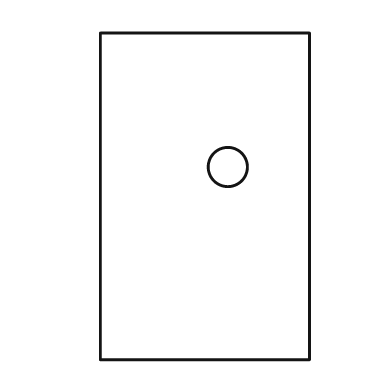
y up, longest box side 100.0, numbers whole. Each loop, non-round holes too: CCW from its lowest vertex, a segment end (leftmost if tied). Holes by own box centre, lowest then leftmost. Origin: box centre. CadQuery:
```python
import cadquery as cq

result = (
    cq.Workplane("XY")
    .moveTo(-32.0, -50.0)
    .lineTo(32.0, -50.0)
    .lineTo(32.0, 50.0)
    .lineTo(-32.0, 50.0)
    .close()
    .moveTo(7.0, 9.0)
    .circle(6.0)
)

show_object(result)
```